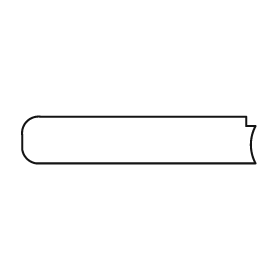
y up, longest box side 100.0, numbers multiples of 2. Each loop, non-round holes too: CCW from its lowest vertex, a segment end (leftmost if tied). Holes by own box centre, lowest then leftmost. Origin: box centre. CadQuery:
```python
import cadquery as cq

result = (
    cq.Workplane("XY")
    .moveTo(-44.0, -10.0)
    .lineTo(50.0, -10.0)
    .threePointArc((48.0, -2.0), (50.0, 6.0))
    .lineTo(46.0, 6.0)
    .lineTo(46.0, 10.0)
    .lineTo(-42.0, 10.0)
    .threePointArc((-48.0, 8.0), (-50.0, 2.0))
    .lineTo(-50.0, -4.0)
    .threePointArc((-48.0, -8.0), (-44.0, -10.0))
    .close()
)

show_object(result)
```